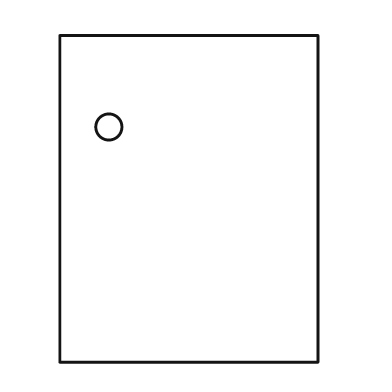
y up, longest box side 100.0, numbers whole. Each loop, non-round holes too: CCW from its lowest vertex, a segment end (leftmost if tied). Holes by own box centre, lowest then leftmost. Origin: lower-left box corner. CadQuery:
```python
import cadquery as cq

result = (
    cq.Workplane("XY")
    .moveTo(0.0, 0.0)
    .lineTo(79.0, 0.0)
    .lineTo(79.0, 100.0)
    .lineTo(0.0, 100.0)
    .close()
    .moveTo(15.0, 72.0)
    .circle(4.0)
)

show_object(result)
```